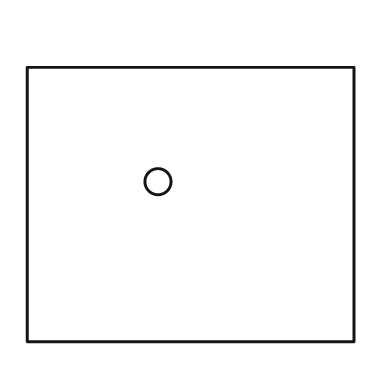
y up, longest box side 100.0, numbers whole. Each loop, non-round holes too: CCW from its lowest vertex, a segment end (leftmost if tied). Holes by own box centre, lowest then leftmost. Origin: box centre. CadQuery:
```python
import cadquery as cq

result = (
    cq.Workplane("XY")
    .moveTo(-50.0, -42.0)
    .lineTo(50.0, -42.0)
    .lineTo(50.0, 42.0)
    .lineTo(-50.0, 42.0)
    .close()
    .moveTo(-10.0, 7.0)
    .circle(4.0)
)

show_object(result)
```